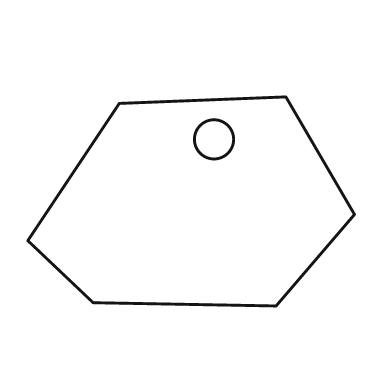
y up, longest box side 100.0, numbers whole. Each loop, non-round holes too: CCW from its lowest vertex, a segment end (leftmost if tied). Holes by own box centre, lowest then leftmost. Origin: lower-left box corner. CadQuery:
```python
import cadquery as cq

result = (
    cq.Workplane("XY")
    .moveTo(76.0, 0.0)
    .lineTo(100.0, 28.0)
    .lineTo(79.0, 64.0)
    .lineTo(28.0, 62.0)
    .lineTo(0.0, 20.0)
    .lineTo(20.0, 1.0)
    .close()
    .moveTo(57.0, 51.0)
    .circle(6.0)
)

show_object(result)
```